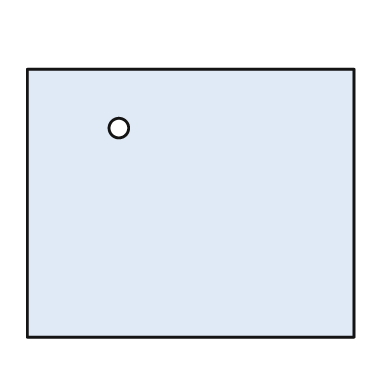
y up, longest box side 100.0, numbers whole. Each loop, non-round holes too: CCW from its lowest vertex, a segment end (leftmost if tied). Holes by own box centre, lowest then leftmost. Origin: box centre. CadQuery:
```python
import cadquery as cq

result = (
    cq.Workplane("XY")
    .moveTo(-50.0, -41.0)
    .lineTo(50.0, -41.0)
    .lineTo(50.0, 41.0)
    .lineTo(-50.0, 41.0)
    .close()
    .moveTo(-22.0, 23.0)
    .circle(3.0)
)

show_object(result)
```